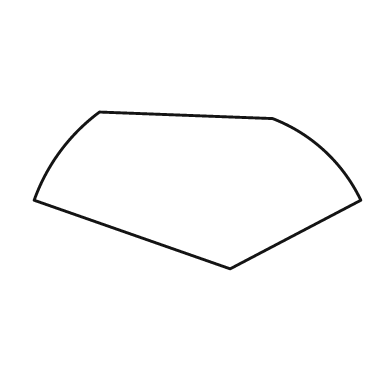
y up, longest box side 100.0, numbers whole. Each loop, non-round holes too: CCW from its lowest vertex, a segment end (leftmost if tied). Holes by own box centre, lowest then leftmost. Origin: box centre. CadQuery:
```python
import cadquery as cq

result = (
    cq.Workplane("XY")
    .moveTo(10.0, -24.0)
    .lineTo(50.0, -3.0)
    .threePointArc((39.0, 12.0), (23.0, 22.0))
    .lineTo(-30.0, 24.0)
    .threePointArc((-42.0, 12.0), (-50.0, -3.0))
    .close()
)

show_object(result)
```